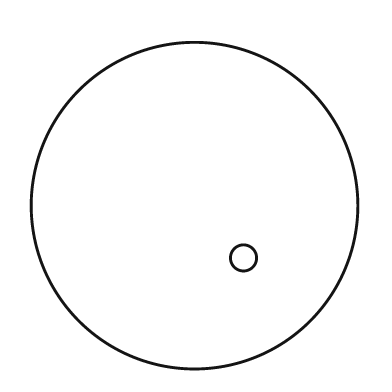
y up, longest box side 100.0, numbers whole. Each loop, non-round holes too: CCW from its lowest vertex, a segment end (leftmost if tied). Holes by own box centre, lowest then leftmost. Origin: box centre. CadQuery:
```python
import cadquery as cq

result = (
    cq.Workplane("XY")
    .moveTo(0.0, 0.0)
    .circle(50.0)
    .moveTo(15.0, -16.0)
    .circle(4.0)
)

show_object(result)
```